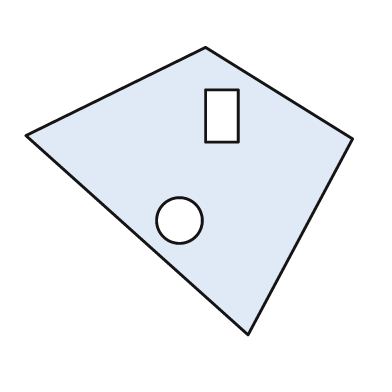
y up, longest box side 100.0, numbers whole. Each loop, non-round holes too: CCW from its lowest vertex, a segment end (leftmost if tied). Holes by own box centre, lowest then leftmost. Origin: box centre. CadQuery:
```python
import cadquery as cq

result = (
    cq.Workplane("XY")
    .moveTo(18.0, -44.0)
    .lineTo(50.0, 16.0)
    .lineTo(5.0, 44.0)
    .lineTo(-50.0, 17.0)
    .close()
    .moveTo(-3.0, -9.0)
    .circle(7.0)
    .moveTo(5.0, 15.0)
    .lineTo(15.0, 15.0)
    .lineTo(15.0, 31.0)
    .lineTo(5.0, 31.0)
    .close()
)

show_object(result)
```